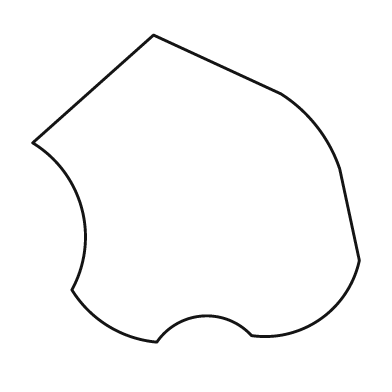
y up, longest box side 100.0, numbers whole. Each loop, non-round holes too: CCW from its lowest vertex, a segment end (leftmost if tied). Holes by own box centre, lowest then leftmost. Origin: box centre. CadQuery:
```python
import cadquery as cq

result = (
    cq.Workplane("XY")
    .moveTo(-12.0, -47.0)
    .threePointArc((2.0, -39.0), (17.0, -45.0))
    .threePointArc((38.0, -40.0), (50.0, -22.0))
    .lineTo(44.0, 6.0)
    .threePointArc((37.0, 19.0), (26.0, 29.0))
    .lineTo(-13.0, 47.0)
    .lineTo(-50.0, 14.0)
    .threePointArc((-35.0, -6.0), (-38.0, -31.0))
    .threePointArc((-27.0, -42.0), (-12.0, -47.0))
    .close()
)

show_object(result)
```